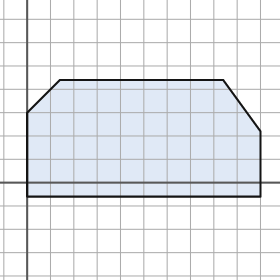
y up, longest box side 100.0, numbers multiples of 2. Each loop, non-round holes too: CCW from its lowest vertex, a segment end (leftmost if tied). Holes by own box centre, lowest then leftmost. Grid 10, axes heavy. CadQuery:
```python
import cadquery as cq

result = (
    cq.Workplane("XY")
    .moveTo(0.0, -6.0)
    .lineTo(100.0, -6.0)
    .lineTo(100.0, 22.0)
    .lineTo(84.0, 44.0)
    .lineTo(14.0, 44.0)
    .lineTo(0.0, 30.0)
    .close()
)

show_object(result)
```